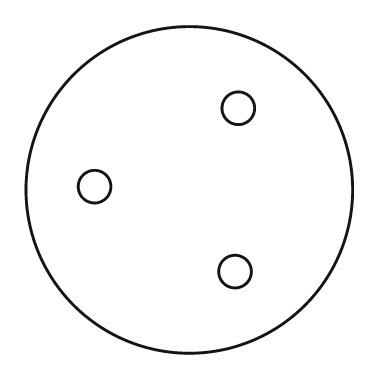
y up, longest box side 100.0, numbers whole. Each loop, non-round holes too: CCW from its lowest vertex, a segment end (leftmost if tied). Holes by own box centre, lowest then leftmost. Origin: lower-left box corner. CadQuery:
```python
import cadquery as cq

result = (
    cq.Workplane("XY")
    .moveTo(50.0, 50.0)
    .circle(50.0)
    .moveTo(64.0, 25.0)
    .circle(5.0)
    .moveTo(21.0, 51.0)
    .circle(5.0)
    .moveTo(65.0, 75.0)
    .circle(5.0)
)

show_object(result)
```